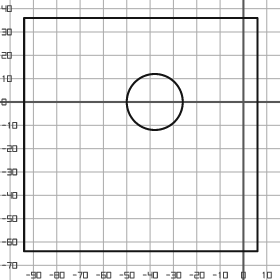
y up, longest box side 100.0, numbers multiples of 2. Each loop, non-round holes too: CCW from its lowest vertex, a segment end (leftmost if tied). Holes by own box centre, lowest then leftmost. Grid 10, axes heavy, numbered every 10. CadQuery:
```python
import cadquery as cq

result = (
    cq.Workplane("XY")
    .moveTo(-94.0, -64.0)
    .lineTo(6.0, -64.0)
    .lineTo(6.0, 36.0)
    .lineTo(-94.0, 36.0)
    .close()
    .moveTo(-38.0, 0.0)
    .circle(12.0)
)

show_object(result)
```